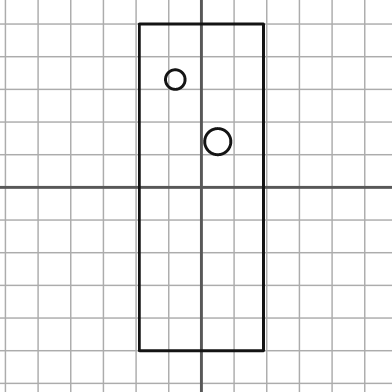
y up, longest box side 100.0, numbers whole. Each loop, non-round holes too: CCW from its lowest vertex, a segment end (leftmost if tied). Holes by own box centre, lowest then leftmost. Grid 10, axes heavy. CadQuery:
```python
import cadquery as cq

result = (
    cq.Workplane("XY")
    .moveTo(-19.0, -50.0)
    .lineTo(19.0, -50.0)
    .lineTo(19.0, 50.0)
    .lineTo(-19.0, 50.0)
    .close()
    .moveTo(5.0, 14.0)
    .circle(4.0)
    .moveTo(-8.0, 33.0)
    .circle(3.0)
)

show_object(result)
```